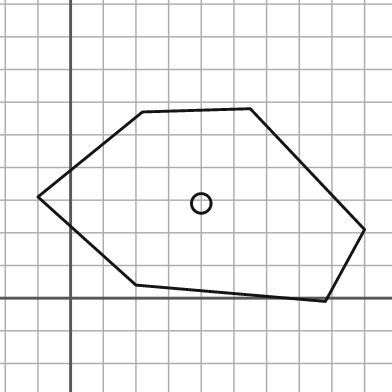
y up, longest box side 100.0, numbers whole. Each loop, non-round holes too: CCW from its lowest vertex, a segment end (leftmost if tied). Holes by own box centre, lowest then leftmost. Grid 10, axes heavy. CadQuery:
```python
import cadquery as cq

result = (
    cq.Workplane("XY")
    .moveTo(78.0, -1.0)
    .lineTo(90.0, 21.0)
    .lineTo(55.0, 58.0)
    .lineTo(22.0, 57.0)
    .lineTo(-10.0, 31.0)
    .lineTo(20.0, 4.0)
    .close()
    .moveTo(40.0, 29.0)
    .circle(3.0)
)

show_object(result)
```